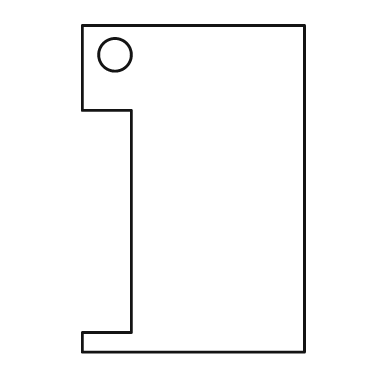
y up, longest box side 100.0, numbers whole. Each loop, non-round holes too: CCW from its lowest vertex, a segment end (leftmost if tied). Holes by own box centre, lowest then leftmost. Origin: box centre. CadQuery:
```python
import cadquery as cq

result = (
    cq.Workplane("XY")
    .moveTo(-34.0, -50.0)
    .lineTo(34.0, -50.0)
    .lineTo(34.0, 50.0)
    .lineTo(-34.0, 50.0)
    .lineTo(-34.0, 24.0)
    .lineTo(-19.0, 24.0)
    .lineTo(-19.0, -44.0)
    .lineTo(-34.0, -44.0)
    .close()
    .moveTo(-24.0, 41.0)
    .circle(5.0)
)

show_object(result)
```